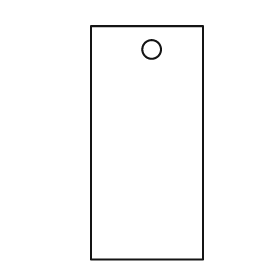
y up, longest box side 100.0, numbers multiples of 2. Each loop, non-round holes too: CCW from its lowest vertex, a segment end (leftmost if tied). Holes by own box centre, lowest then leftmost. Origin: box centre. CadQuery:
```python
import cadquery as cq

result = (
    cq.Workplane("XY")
    .moveTo(-24.0, -50.0)
    .lineTo(24.0, -50.0)
    .lineTo(24.0, 50.0)
    .lineTo(-24.0, 50.0)
    .close()
    .moveTo(2.0, 40.0)
    .circle(4.0)
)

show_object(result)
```